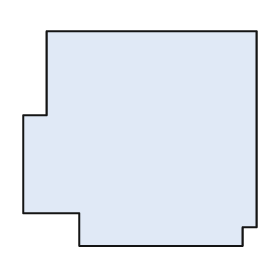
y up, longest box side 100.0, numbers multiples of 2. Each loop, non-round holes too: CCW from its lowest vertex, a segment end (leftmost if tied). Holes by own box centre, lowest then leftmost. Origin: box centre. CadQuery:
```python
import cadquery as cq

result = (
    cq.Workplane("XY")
    .moveTo(-26.0, -46.0)
    .lineTo(44.0, -46.0)
    .lineTo(44.0, -38.0)
    .lineTo(50.0, -38.0)
    .lineTo(50.0, 46.0)
    .lineTo(-40.0, 46.0)
    .lineTo(-40.0, 10.0)
    .lineTo(-50.0, 10.0)
    .lineTo(-50.0, -32.0)
    .lineTo(-26.0, -32.0)
    .close()
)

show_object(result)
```